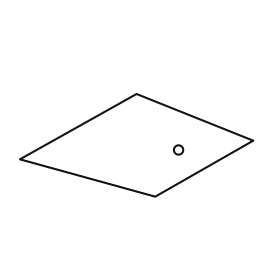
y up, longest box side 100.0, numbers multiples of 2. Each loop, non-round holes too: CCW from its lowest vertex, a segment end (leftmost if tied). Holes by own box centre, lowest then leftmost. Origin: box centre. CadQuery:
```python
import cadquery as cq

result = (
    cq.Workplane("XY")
    .moveTo(8.0, -22.0)
    .lineTo(50.0, 2.0)
    .lineTo(0.0, 22.0)
    .lineTo(-50.0, -6.0)
    .close()
    .moveTo(18.0, -2.0)
    .circle(2.0)
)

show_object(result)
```